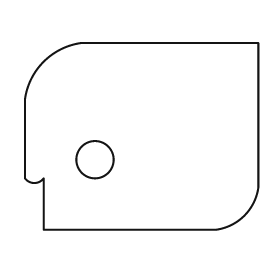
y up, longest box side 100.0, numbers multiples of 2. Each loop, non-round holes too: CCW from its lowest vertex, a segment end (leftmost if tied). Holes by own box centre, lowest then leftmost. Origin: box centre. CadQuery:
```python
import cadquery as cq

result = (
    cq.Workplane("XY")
    .moveTo(-42.0, -40.0)
    .lineTo(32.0, -40.0)
    .threePointArc((44.0, -34.0), (50.0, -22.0))
    .lineTo(50.0, 40.0)
    .lineTo(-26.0, 40.0)
    .threePointArc((-42.0, 32.0), (-50.0, 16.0))
    .lineTo(-50.0, -18.0)
    .threePointArc((-46.0, -20.0), (-42.0, -18.0))
    .close()
    .moveTo(-20.0, -10.0)
    .circle(8.0)
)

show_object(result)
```